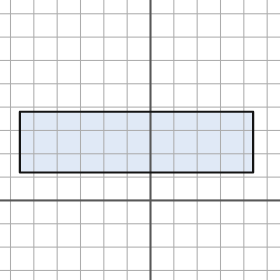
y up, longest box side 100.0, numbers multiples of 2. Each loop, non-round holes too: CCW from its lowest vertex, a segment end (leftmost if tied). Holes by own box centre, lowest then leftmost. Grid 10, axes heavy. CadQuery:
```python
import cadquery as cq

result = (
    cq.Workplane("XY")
    .moveTo(-56.0, 12.0)
    .lineTo(44.0, 12.0)
    .lineTo(44.0, 38.0)
    .lineTo(-56.0, 38.0)
    .close()
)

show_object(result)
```